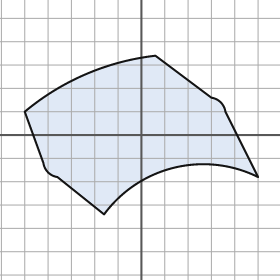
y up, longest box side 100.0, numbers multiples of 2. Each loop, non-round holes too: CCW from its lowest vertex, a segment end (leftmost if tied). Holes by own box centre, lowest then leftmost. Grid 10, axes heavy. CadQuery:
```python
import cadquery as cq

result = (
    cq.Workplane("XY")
    .moveTo(-16.0, -34.0)
    .threePointArc((14.0, -14.0), (50.0, -18.0))
    .lineTo(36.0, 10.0)
    .threePointArc((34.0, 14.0), (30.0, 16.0))
    .lineTo(6.0, 34.0)
    .threePointArc((-24.0, 26.0), (-50.0, 10.0))
    .lineTo(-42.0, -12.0)
    .threePointArc((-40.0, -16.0), (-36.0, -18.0))
    .close()
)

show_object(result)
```